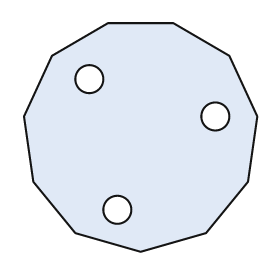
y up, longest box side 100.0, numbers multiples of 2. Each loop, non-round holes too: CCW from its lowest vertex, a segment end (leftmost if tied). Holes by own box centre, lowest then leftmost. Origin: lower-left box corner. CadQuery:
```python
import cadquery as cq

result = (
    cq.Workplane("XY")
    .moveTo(50.0, 0.0)
    .lineTo(78.0, 8.0)
    .lineTo(96.0, 30.0)
    .lineTo(100.0, 58.0)
    .lineTo(88.0, 84.0)
    .lineTo(64.0, 98.0)
    .lineTo(36.0, 98.0)
    .lineTo(12.0, 84.0)
    .lineTo(0.0, 58.0)
    .lineTo(4.0, 30.0)
    .lineTo(22.0, 8.0)
    .close()
    .moveTo(40.0, 18.0)
    .circle(6.0)
    .moveTo(82.0, 58.0)
    .circle(6.0)
    .moveTo(28.0, 74.0)
    .circle(6.0)
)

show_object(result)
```